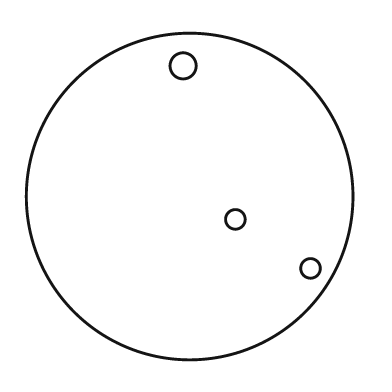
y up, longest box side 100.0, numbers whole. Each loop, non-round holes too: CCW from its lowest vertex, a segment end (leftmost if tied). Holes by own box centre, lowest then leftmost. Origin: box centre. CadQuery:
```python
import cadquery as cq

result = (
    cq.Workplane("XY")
    .moveTo(0.0, 0.0)
    .circle(50.0)
    .moveTo(37.0, -22.0)
    .circle(3.0)
    .moveTo(14.0, -7.0)
    .circle(3.0)
    .moveTo(-2.0, 40.0)
    .circle(4.0)
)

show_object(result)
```